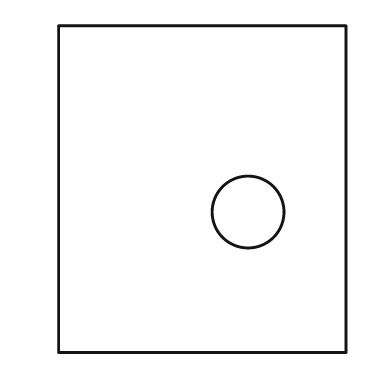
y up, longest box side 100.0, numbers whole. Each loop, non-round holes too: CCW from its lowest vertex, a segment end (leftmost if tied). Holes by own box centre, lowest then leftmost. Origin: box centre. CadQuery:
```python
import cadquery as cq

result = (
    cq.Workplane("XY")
    .moveTo(-44.0, -50.0)
    .lineTo(44.0, -50.0)
    .lineTo(44.0, 50.0)
    .lineTo(-44.0, 50.0)
    .close()
    .moveTo(14.0, -7.0)
    .circle(11.0)
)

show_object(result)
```